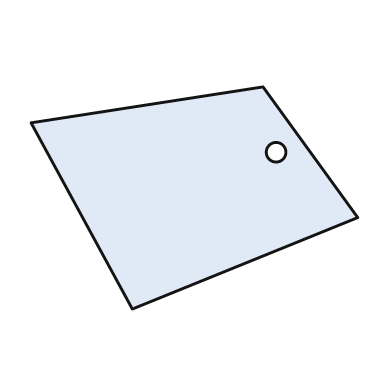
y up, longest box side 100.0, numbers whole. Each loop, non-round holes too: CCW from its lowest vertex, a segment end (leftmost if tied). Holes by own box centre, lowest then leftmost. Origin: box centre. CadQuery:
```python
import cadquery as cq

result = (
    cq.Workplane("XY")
    .moveTo(-19.0, -34.0)
    .lineTo(50.0, -6.0)
    .lineTo(21.0, 34.0)
    .lineTo(-50.0, 23.0)
    .close()
    .moveTo(25.0, 14.0)
    .circle(3.0)
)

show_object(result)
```